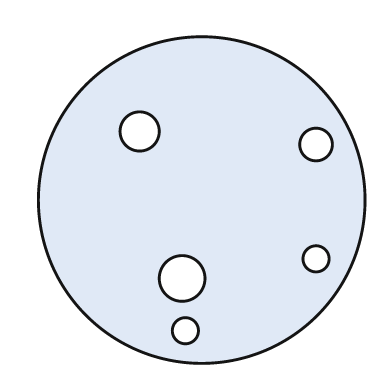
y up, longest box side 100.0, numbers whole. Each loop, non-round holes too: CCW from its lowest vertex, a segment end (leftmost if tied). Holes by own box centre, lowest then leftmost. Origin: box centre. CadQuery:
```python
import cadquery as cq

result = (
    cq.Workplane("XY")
    .moveTo(0.0, 0.0)
    .circle(50.0)
    .moveTo(-5.0, -40.0)
    .circle(4.0)
    .moveTo(-6.0, -24.0)
    .circle(7.0)
    .moveTo(35.0, -18.0)
    .circle(4.0)
    .moveTo(35.0, 17.0)
    .circle(5.0)
    .moveTo(-19.0, 21.0)
    .circle(6.0)
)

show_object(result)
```